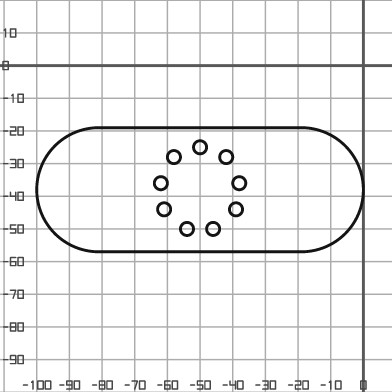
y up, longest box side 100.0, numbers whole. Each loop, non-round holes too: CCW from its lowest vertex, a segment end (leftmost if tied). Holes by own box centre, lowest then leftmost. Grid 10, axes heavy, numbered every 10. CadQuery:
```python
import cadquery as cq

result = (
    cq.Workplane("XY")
    .moveTo(-81.0, -57.0)
    .lineTo(-19.0, -57.0)
    .threePointArc((0.0, -38.0), (-19.0, -19.0))
    .lineTo(-81.0, -19.0)
    .threePointArc((-100.0, -38.0), (-81.0, -57.0))
    .close()
    .moveTo(-54.0, -50.0)
    .circle(2.0)
    .moveTo(-46.0, -50.0)
    .circle(2.0)
    .moveTo(-61.0, -44.0)
    .circle(2.0)
    .moveTo(-39.0, -44.0)
    .circle(2.0)
    .moveTo(-62.0, -36.0)
    .circle(2.0)
    .moveTo(-38.0, -36.0)
    .circle(2.0)
    .moveTo(-58.0, -28.0)
    .circle(2.0)
    .moveTo(-42.0, -28.0)
    .circle(2.0)
    .moveTo(-50.0, -25.0)
    .circle(2.0)
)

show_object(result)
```